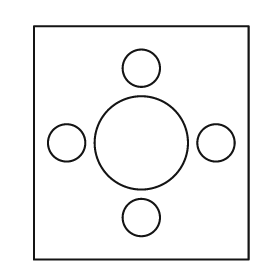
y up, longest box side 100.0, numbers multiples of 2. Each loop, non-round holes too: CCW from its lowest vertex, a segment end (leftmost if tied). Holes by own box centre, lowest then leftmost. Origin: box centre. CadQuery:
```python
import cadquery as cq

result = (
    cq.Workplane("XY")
    .moveTo(-46.0, -50.0)
    .lineTo(46.0, -50.0)
    .lineTo(46.0, 50.0)
    .lineTo(-46.0, 50.0)
    .close()
    .moveTo(0.0, -32.0)
    .circle(8.0)
    .moveTo(-32.0, 0.0)
    .circle(8.0)
    .moveTo(0.0, 0.0)
    .circle(20.0)
    .moveTo(32.0, 0.0)
    .circle(8.0)
    .moveTo(0.0, 32.0)
    .circle(8.0)
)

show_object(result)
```